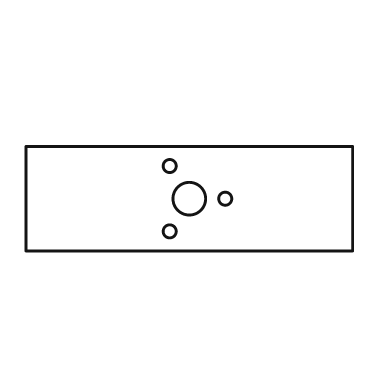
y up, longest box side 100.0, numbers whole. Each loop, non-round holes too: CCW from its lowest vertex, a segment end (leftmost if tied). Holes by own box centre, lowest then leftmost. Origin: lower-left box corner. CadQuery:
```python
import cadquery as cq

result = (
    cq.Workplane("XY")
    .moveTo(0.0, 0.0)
    .lineTo(100.0, 0.0)
    .lineTo(100.0, 32.0)
    .lineTo(0.0, 32.0)
    .close()
    .moveTo(44.0, 6.0)
    .circle(2.0)
    .moveTo(50.0, 16.0)
    .circle(5.0)
    .moveTo(61.0, 16.0)
    .circle(2.0)
    .moveTo(44.0, 26.0)
    .circle(2.0)
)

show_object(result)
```